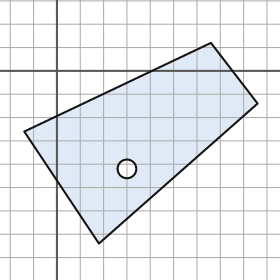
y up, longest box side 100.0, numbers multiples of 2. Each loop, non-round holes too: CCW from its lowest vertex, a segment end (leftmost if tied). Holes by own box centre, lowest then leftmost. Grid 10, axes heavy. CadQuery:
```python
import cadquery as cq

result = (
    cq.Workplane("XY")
    .moveTo(18.0, -74.0)
    .lineTo(86.0, -14.0)
    .lineTo(66.0, 12.0)
    .lineTo(-14.0, -26.0)
    .close()
    .moveTo(30.0, -42.0)
    .circle(4.0)
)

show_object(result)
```